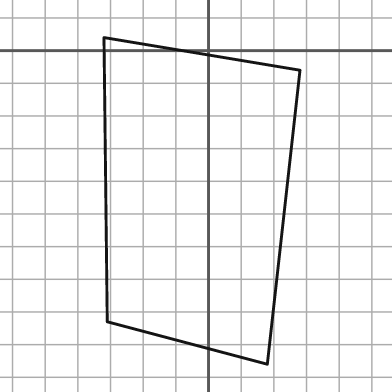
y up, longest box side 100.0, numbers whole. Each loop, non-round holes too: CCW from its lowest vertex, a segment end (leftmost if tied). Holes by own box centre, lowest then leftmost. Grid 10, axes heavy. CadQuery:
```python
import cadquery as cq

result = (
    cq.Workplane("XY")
    .moveTo(18.0, -96.0)
    .lineTo(28.0, -6.0)
    .lineTo(-32.0, 4.0)
    .lineTo(-31.0, -83.0)
    .close()
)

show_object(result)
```